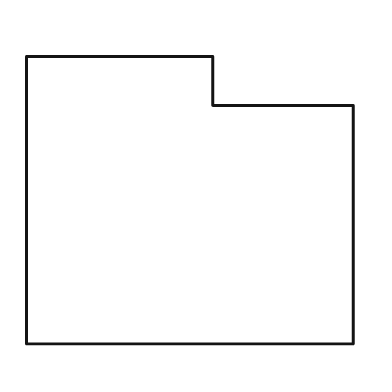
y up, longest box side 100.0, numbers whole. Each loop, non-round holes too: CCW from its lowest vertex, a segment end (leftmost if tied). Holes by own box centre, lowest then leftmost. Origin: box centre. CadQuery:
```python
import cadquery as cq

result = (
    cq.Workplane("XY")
    .moveTo(-50.0, -44.0)
    .lineTo(50.0, -44.0)
    .lineTo(50.0, 29.0)
    .lineTo(7.0, 29.0)
    .lineTo(7.0, 44.0)
    .lineTo(-50.0, 44.0)
    .close()
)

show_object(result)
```